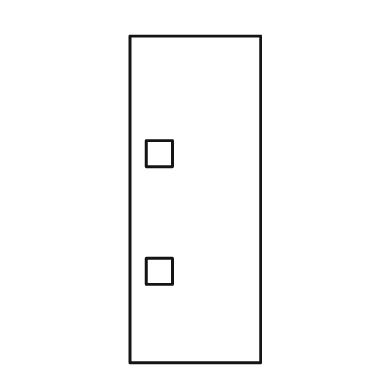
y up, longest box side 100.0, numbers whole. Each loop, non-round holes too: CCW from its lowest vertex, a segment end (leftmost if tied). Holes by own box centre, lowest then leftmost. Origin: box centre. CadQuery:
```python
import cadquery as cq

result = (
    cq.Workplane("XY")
    .moveTo(-20.0, -50.0)
    .lineTo(20.0, -50.0)
    .lineTo(20.0, 50.0)
    .lineTo(-20.0, 50.0)
    .close()
    .moveTo(-15.0, -26.0)
    .lineTo(-7.0, -26.0)
    .lineTo(-7.0, -18.0)
    .lineTo(-15.0, -18.0)
    .close()
    .moveTo(-15.0, 10.0)
    .lineTo(-7.0, 10.0)
    .lineTo(-7.0, 18.0)
    .lineTo(-15.0, 18.0)
    .close()
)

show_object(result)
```